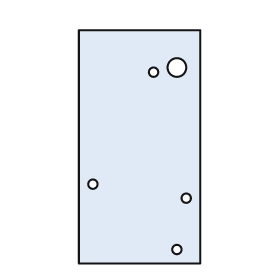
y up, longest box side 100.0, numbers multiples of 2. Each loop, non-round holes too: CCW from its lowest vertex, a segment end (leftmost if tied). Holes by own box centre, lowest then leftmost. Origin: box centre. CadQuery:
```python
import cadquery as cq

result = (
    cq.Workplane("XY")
    .moveTo(-26.0, -50.0)
    .lineTo(26.0, -50.0)
    .lineTo(26.0, 50.0)
    .lineTo(-26.0, 50.0)
    .close()
    .moveTo(16.0, -44.0)
    .circle(2.0)
    .moveTo(20.0, -22.0)
    .circle(2.0)
    .moveTo(-20.0, -16.0)
    .circle(2.0)
    .moveTo(6.0, 32.0)
    .circle(2.0)
    .moveTo(16.0, 34.0)
    .circle(4.0)
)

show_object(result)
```